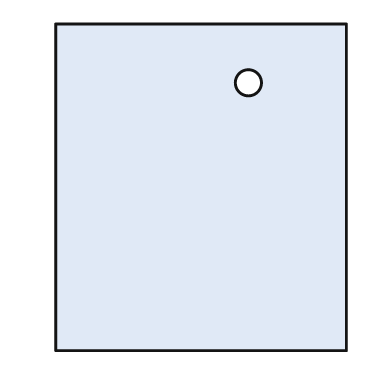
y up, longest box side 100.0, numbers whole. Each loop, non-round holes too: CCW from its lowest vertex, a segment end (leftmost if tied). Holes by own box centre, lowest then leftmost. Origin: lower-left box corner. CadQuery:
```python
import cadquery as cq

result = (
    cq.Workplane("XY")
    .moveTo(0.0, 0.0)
    .lineTo(89.0, 0.0)
    .lineTo(89.0, 100.0)
    .lineTo(0.0, 100.0)
    .close()
    .moveTo(59.0, 82.0)
    .circle(4.0)
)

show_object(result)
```